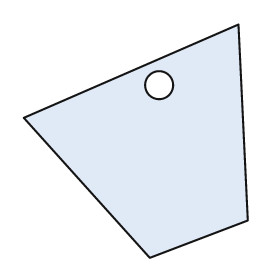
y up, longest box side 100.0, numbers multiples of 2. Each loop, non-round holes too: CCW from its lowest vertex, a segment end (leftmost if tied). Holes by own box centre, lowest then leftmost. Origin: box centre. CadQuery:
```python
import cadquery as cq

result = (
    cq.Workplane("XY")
    .moveTo(6.0, -50.0)
    .lineTo(48.0, -34.0)
    .lineTo(44.0, 50.0)
    .lineTo(-48.0, 10.0)
    .close()
    .moveTo(10.0, 24.0)
    .circle(6.0)
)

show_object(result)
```